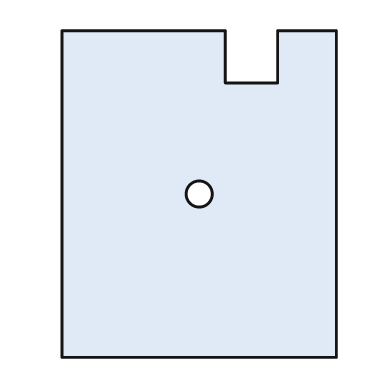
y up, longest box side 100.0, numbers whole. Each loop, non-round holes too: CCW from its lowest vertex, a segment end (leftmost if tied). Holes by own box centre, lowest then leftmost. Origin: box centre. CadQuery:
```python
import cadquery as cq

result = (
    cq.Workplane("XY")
    .moveTo(-42.0, -50.0)
    .lineTo(42.0, -50.0)
    .lineTo(42.0, 50.0)
    .lineTo(24.0, 50.0)
    .lineTo(24.0, 34.0)
    .lineTo(8.0, 34.0)
    .lineTo(8.0, 50.0)
    .lineTo(-42.0, 50.0)
    .close()
    .moveTo(0.0, 0.0)
    .circle(4.0)
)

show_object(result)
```